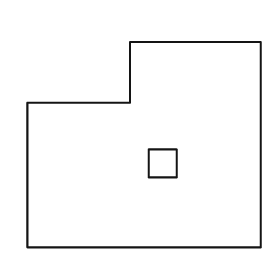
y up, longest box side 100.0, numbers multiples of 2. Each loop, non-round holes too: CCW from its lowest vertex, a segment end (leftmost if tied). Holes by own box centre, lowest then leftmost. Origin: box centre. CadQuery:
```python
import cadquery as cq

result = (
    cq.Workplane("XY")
    .moveTo(-50.0, -44.0)
    .lineTo(50.0, -44.0)
    .lineTo(50.0, 44.0)
    .lineTo(-6.0, 44.0)
    .lineTo(-6.0, 18.0)
    .lineTo(-50.0, 18.0)
    .close()
    .moveTo(2.0, -14.0)
    .lineTo(14.0, -14.0)
    .lineTo(14.0, -2.0)
    .lineTo(2.0, -2.0)
    .close()
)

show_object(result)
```